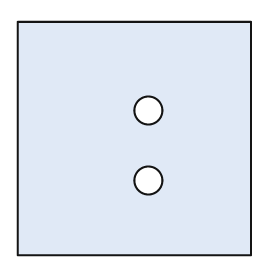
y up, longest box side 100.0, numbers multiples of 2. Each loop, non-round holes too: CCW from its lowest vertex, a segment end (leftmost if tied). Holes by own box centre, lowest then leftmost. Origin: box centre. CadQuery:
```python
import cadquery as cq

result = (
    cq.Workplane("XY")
    .moveTo(-50.0, -50.0)
    .lineTo(50.0, -50.0)
    .lineTo(50.0, 50.0)
    .lineTo(-50.0, 50.0)
    .close()
    .moveTo(6.0, -18.0)
    .circle(6.0)
    .moveTo(6.0, 12.0)
    .circle(6.0)
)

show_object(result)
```